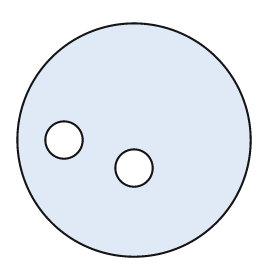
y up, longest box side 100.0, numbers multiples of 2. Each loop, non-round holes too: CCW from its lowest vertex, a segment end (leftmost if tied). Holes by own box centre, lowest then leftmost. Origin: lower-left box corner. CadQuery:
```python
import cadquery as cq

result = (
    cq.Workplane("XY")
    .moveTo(50.0, 50.0)
    .circle(50.0)
    .moveTo(50.0, 38.0)
    .circle(8.0)
    .moveTo(20.0, 50.0)
    .circle(8.0)
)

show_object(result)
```